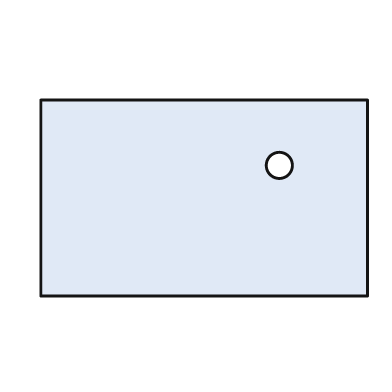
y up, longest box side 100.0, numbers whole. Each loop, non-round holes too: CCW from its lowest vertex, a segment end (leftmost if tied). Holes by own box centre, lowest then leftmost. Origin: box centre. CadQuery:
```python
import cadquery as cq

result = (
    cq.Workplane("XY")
    .moveTo(-50.0, -30.0)
    .lineTo(50.0, -30.0)
    .lineTo(50.0, 30.0)
    .lineTo(-50.0, 30.0)
    .close()
    .moveTo(23.0, 10.0)
    .circle(4.0)
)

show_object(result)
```